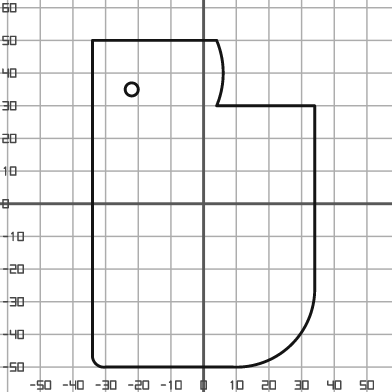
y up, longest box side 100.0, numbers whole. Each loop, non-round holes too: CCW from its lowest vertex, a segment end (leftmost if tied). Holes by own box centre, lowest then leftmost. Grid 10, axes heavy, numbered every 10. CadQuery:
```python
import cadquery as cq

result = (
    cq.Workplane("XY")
    .moveTo(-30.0, -50.0)
    .lineTo(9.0, -50.0)
    .threePointArc((27.0, -43.0), (34.0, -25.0))
    .lineTo(34.0, 30.0)
    .lineTo(4.0, 30.0)
    .threePointArc((6.0, 40.0), (4.0, 50.0))
    .lineTo(-34.0, 50.0)
    .lineTo(-34.0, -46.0)
    .threePointArc((-33.0, -49.0), (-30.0, -50.0))
    .close()
    .moveTo(-22.0, 35.0)
    .circle(2.0)
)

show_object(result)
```